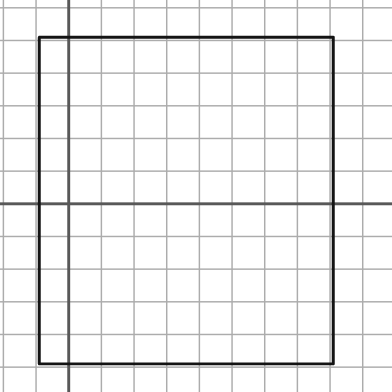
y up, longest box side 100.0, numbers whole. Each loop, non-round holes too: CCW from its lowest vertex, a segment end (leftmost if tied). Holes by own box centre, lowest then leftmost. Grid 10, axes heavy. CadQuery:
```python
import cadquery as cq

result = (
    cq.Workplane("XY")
    .moveTo(-9.0, -49.0)
    .lineTo(81.0, -49.0)
    .lineTo(81.0, 51.0)
    .lineTo(-9.0, 51.0)
    .close()
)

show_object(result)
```